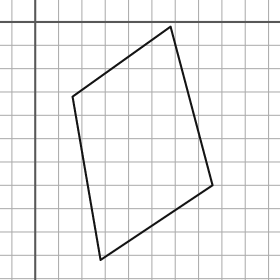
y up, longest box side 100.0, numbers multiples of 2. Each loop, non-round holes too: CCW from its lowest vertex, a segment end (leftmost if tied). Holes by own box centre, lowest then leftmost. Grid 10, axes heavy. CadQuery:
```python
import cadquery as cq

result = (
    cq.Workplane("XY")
    .moveTo(28.0, -102.0)
    .lineTo(76.0, -70.0)
    .lineTo(58.0, -2.0)
    .lineTo(16.0, -32.0)
    .close()
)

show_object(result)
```